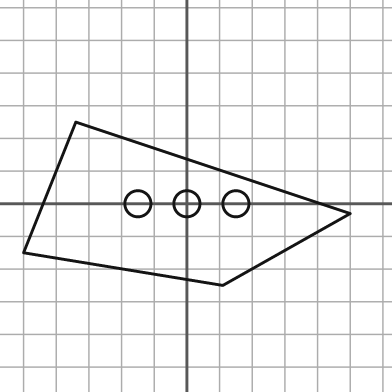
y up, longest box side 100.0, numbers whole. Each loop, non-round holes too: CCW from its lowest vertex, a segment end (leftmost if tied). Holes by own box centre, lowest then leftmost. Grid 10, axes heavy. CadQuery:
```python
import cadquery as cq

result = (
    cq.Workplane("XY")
    .moveTo(11.0, -25.0)
    .lineTo(50.0, -3.0)
    .lineTo(-34.0, 25.0)
    .lineTo(-50.0, -15.0)
    .close()
    .moveTo(-15.0, 0.0)
    .circle(4.0)
    .moveTo(0.0, 0.0)
    .circle(4.0)
    .moveTo(15.0, 0.0)
    .circle(4.0)
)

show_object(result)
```